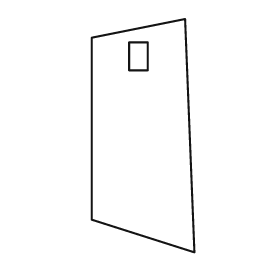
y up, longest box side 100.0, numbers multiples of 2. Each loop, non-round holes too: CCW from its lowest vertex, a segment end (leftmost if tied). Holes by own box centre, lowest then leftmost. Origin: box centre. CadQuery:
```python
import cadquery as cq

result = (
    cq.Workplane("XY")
    .moveTo(22.0, -50.0)
    .lineTo(18.0, 50.0)
    .lineTo(-22.0, 42.0)
    .lineTo(-22.0, -36.0)
    .close()
    .moveTo(-6.0, 28.0)
    .lineTo(2.0, 28.0)
    .lineTo(2.0, 40.0)
    .lineTo(-6.0, 40.0)
    .close()
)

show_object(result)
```